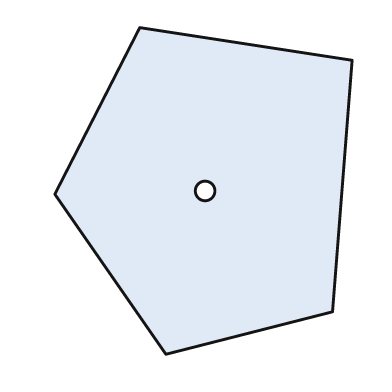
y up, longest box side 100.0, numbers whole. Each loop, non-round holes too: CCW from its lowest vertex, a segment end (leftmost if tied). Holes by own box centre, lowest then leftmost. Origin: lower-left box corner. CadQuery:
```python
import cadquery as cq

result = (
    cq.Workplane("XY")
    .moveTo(34.0, 0.0)
    .lineTo(85.0, 13.0)
    .lineTo(91.0, 90.0)
    .lineTo(26.0, 100.0)
    .lineTo(0.0, 49.0)
    .close()
    .moveTo(46.0, 50.0)
    .circle(3.0)
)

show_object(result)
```